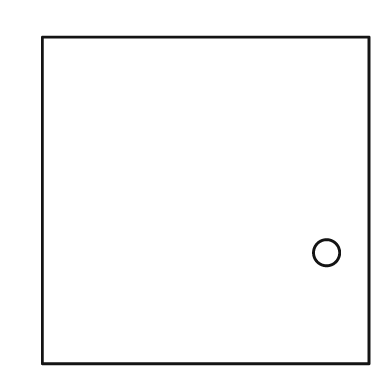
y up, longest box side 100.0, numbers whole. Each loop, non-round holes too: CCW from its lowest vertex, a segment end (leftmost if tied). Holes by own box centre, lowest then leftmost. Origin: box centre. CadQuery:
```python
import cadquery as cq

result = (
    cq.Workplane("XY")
    .moveTo(-50.0, -50.0)
    .lineTo(50.0, -50.0)
    .lineTo(50.0, 50.0)
    .lineTo(-50.0, 50.0)
    .close()
    .moveTo(37.0, -16.0)
    .circle(4.0)
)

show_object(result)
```